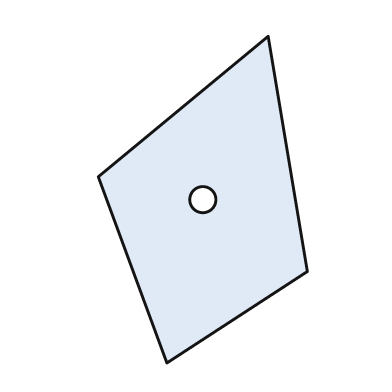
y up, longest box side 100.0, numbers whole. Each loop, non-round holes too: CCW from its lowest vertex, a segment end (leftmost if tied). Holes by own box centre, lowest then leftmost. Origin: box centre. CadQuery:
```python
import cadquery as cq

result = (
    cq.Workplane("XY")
    .moveTo(-11.0, -50.0)
    .lineTo(32.0, -22.0)
    .lineTo(20.0, 50.0)
    .lineTo(-32.0, 7.0)
    .close()
    .moveTo(0.0, 0.0)
    .circle(4.0)
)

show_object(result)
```